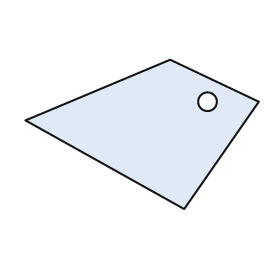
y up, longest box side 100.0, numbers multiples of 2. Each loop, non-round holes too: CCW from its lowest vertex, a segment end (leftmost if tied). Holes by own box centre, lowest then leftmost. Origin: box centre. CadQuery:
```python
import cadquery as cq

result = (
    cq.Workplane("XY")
    .moveTo(18.0, -32.0)
    .lineTo(50.0, 14.0)
    .lineTo(12.0, 32.0)
    .lineTo(-50.0, 6.0)
    .close()
    .moveTo(28.0, 14.0)
    .circle(4.0)
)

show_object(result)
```